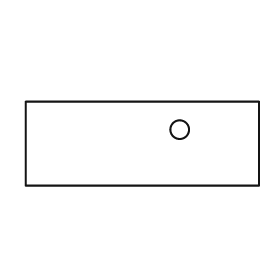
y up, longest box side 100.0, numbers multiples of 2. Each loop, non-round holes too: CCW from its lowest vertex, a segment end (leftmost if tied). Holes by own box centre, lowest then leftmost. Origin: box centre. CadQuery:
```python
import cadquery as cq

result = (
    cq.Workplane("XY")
    .moveTo(-50.0, -18.0)
    .lineTo(50.0, -18.0)
    .lineTo(50.0, 18.0)
    .lineTo(-50.0, 18.0)
    .close()
    .moveTo(16.0, 6.0)
    .circle(4.0)
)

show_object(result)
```